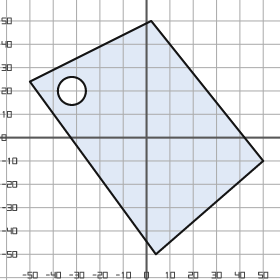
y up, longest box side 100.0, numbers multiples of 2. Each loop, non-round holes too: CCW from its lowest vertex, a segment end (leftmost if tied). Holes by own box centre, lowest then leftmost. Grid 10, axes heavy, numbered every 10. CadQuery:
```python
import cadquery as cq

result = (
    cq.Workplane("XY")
    .moveTo(4.0, -50.0)
    .lineTo(50.0, -10.0)
    .lineTo(2.0, 50.0)
    .lineTo(-50.0, 24.0)
    .close()
    .moveTo(-32.0, 20.0)
    .circle(6.0)
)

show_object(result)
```